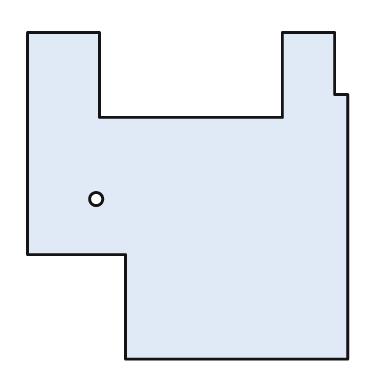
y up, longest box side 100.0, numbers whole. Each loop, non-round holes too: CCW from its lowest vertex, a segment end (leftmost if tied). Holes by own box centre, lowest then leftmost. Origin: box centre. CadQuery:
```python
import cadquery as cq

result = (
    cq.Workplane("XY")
    .moveTo(-19.0, -50.0)
    .lineTo(49.0, -50.0)
    .lineTo(49.0, 31.0)
    .lineTo(45.0, 31.0)
    .lineTo(45.0, 50.0)
    .lineTo(29.0, 50.0)
    .lineTo(29.0, 24.0)
    .lineTo(-27.0, 24.0)
    .lineTo(-27.0, 50.0)
    .lineTo(-49.0, 50.0)
    .lineTo(-49.0, -18.0)
    .lineTo(-19.0, -18.0)
    .close()
    .moveTo(-28.0, -1.0)
    .circle(2.0)
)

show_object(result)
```